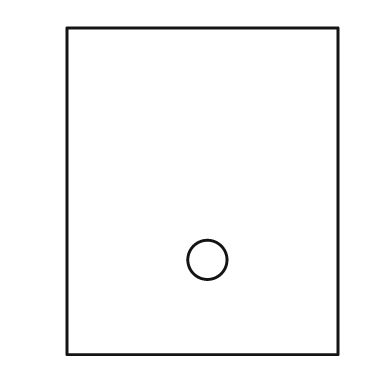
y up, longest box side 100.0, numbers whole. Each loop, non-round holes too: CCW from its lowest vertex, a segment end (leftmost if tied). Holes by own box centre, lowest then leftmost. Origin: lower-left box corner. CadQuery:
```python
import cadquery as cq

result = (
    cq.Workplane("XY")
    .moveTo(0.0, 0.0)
    .lineTo(83.0, 0.0)
    .lineTo(83.0, 100.0)
    .lineTo(0.0, 100.0)
    .close()
    .moveTo(43.0, 29.0)
    .circle(6.0)
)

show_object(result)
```